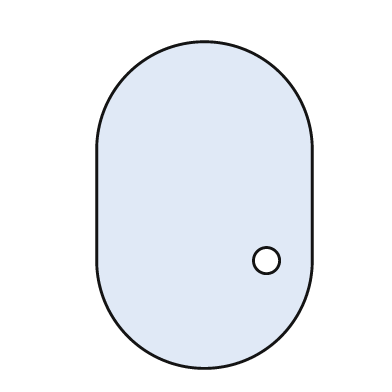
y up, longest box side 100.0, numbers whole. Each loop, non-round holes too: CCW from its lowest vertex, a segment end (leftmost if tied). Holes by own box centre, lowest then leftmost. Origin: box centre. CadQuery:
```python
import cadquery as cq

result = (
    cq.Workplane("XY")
    .moveTo(-33.0, -17.0)
    .threePointArc((0.0, -50.0), (33.0, -17.0))
    .lineTo(33.0, 17.0)
    .threePointArc((0.0, 50.0), (-33.0, 17.0))
    .close()
    .moveTo(19.0, -17.0)
    .circle(4.0)
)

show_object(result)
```